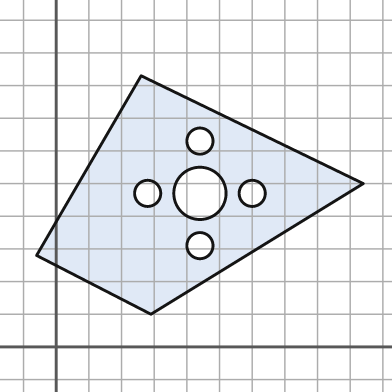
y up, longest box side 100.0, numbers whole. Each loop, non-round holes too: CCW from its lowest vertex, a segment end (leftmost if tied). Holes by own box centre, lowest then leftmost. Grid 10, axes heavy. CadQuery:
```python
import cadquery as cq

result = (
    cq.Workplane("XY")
    .moveTo(29.0, 10.0)
    .lineTo(94.0, 50.0)
    .lineTo(26.0, 83.0)
    .lineTo(-6.0, 28.0)
    .close()
    .moveTo(44.0, 31.0)
    .circle(4.0)
    .moveTo(28.0, 47.0)
    .circle(4.0)
    .moveTo(44.0, 47.0)
    .circle(8.0)
    .moveTo(60.0, 47.0)
    .circle(4.0)
    .moveTo(44.0, 63.0)
    .circle(4.0)
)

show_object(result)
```